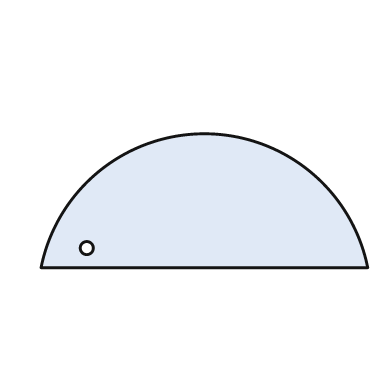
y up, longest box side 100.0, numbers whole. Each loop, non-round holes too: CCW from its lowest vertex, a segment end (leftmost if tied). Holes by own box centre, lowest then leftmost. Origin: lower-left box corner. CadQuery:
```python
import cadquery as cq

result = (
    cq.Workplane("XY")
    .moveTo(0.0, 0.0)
    .lineTo(100.0, 0.0)
    .threePointArc((50.0, 41.0), (0.0, 0.0))
    .close()
    .moveTo(14.0, 6.0)
    .circle(2.0)
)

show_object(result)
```